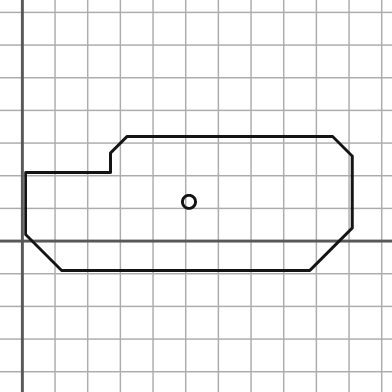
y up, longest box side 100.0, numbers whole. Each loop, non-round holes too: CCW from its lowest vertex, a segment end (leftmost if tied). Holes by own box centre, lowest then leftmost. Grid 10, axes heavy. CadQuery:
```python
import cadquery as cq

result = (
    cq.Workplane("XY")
    .moveTo(12.0, -9.0)
    .lineTo(88.0, -9.0)
    .lineTo(101.0, 4.0)
    .lineTo(101.0, 26.0)
    .lineTo(95.0, 32.0)
    .lineTo(32.0, 32.0)
    .lineTo(27.0, 27.0)
    .lineTo(27.0, 21.0)
    .lineTo(1.0, 21.0)
    .lineTo(1.0, 2.0)
    .close()
    .moveTo(51.0, 12.0)
    .circle(2.0)
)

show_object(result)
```